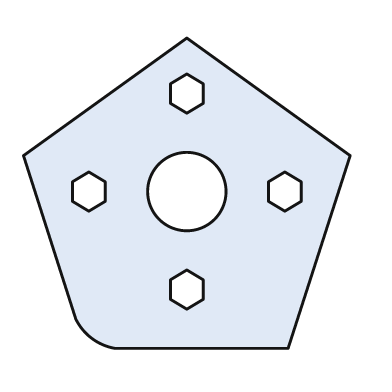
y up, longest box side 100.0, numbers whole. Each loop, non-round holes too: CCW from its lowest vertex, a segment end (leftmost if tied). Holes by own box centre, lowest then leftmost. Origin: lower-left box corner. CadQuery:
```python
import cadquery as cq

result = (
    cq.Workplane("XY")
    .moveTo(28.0, 0.0)
    .lineTo(81.0, 0.0)
    .lineTo(100.0, 59.0)
    .lineTo(50.0, 95.0)
    .lineTo(0.0, 59.0)
    .lineTo(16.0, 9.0)
    .threePointArc((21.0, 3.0), (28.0, 0.0))
    .close()
    .moveTo(50.0, 12.0)
    .lineTo(55.0, 15.0)
    .lineTo(55.0, 21.0)
    .lineTo(50.0, 24.0)
    .lineTo(45.0, 21.0)
    .lineTo(45.0, 15.0)
    .close()
    .moveTo(20.0, 42.0)
    .lineTo(25.0, 45.0)
    .lineTo(25.0, 51.0)
    .lineTo(20.0, 54.0)
    .lineTo(15.0, 51.0)
    .lineTo(15.0, 45.0)
    .close()
    .moveTo(50.0, 48.0)
    .circle(12.0)
    .moveTo(80.0, 42.0)
    .lineTo(85.0, 45.0)
    .lineTo(85.0, 51.0)
    .lineTo(80.0, 54.0)
    .lineTo(75.0, 51.0)
    .lineTo(75.0, 45.0)
    .close()
    .moveTo(50.0, 72.0)
    .lineTo(55.0, 75.0)
    .lineTo(55.0, 81.0)
    .lineTo(50.0, 84.0)
    .lineTo(45.0, 81.0)
    .lineTo(45.0, 75.0)
    .close()
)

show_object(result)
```